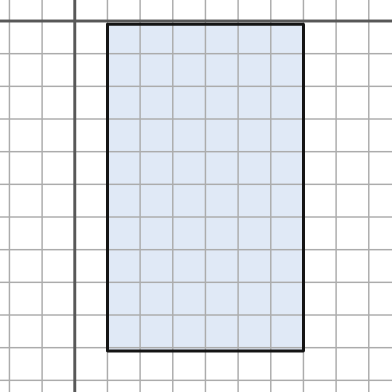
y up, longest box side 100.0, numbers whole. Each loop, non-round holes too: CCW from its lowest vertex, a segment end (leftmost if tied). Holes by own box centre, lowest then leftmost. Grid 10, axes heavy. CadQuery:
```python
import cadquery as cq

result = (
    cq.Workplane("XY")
    .moveTo(10.0, -101.0)
    .lineTo(70.0, -101.0)
    .lineTo(70.0, -1.0)
    .lineTo(10.0, -1.0)
    .close()
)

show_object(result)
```